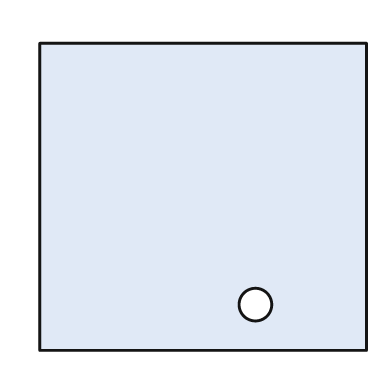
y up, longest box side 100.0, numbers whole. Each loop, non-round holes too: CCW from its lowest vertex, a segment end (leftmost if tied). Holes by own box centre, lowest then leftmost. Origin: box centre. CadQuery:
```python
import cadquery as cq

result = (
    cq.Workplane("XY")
    .moveTo(-50.0, -47.0)
    .lineTo(50.0, -47.0)
    .lineTo(50.0, 47.0)
    .lineTo(-50.0, 47.0)
    .close()
    .moveTo(16.0, -33.0)
    .circle(5.0)
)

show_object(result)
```